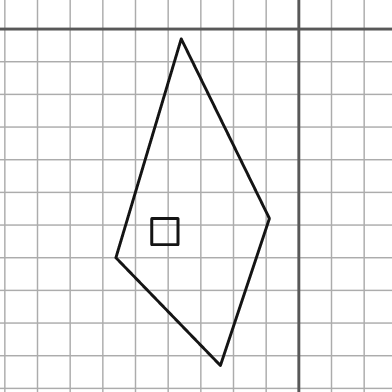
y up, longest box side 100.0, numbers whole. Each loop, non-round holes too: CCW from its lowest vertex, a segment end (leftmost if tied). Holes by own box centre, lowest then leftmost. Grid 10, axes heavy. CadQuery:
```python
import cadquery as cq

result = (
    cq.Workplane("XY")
    .moveTo(-24.0, -103.0)
    .lineTo(-9.0, -58.0)
    .lineTo(-36.0, -3.0)
    .lineTo(-56.0, -70.0)
    .close()
    .moveTo(-45.0, -66.0)
    .lineTo(-37.0, -66.0)
    .lineTo(-37.0, -58.0)
    .lineTo(-45.0, -58.0)
    .close()
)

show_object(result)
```